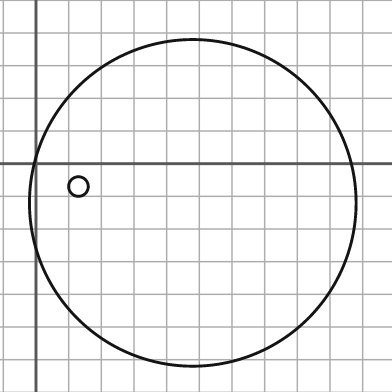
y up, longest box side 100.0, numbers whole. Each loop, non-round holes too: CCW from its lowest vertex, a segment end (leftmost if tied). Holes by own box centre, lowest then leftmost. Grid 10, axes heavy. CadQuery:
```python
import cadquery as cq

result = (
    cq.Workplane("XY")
    .moveTo(48.0, -12.0)
    .circle(50.0)
    .moveTo(13.0, -7.0)
    .circle(3.0)
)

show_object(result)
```